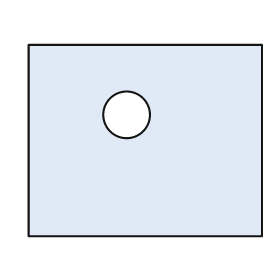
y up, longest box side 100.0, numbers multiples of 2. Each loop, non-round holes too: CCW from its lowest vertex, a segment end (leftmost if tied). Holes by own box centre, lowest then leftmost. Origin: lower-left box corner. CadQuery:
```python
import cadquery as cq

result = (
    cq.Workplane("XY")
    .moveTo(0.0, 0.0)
    .lineTo(100.0, 0.0)
    .lineTo(100.0, 82.0)
    .lineTo(0.0, 82.0)
    .close()
    .moveTo(42.0, 52.0)
    .circle(10.0)
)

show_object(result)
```